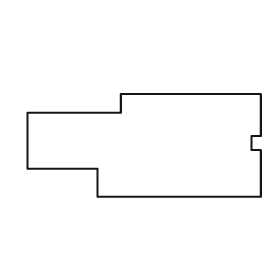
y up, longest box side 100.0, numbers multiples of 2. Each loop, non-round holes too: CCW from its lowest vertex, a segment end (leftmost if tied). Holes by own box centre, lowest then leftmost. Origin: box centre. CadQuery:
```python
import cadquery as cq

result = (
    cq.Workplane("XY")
    .moveTo(-20.0, -22.0)
    .lineTo(50.0, -22.0)
    .lineTo(50.0, -2.0)
    .lineTo(46.0, -2.0)
    .lineTo(46.0, 4.0)
    .lineTo(50.0, 4.0)
    .lineTo(50.0, 22.0)
    .lineTo(-10.0, 22.0)
    .lineTo(-10.0, 14.0)
    .lineTo(-50.0, 14.0)
    .lineTo(-50.0, -10.0)
    .lineTo(-20.0, -10.0)
    .close()
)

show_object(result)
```